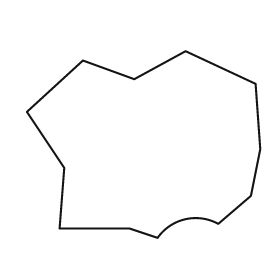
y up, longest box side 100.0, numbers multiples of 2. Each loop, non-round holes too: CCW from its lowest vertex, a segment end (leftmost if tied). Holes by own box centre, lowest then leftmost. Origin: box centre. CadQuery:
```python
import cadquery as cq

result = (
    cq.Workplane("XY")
    .moveTo(6.0, -40.0)
    .threePointArc((18.0, -32.0), (32.0, -34.0))
    .lineTo(46.0, -22.0)
    .lineTo(50.0, -2.0)
    .lineTo(48.0, 26.0)
    .lineTo(18.0, 40.0)
    .lineTo(-4.0, 28.0)
    .lineTo(-26.0, 36.0)
    .lineTo(-50.0, 14.0)
    .lineTo(-34.0, -10.0)
    .lineTo(-36.0, -36.0)
    .lineTo(-6.0, -36.0)
    .close()
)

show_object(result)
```